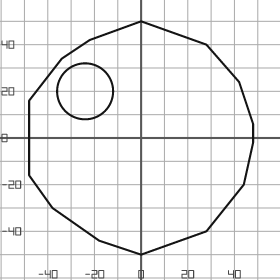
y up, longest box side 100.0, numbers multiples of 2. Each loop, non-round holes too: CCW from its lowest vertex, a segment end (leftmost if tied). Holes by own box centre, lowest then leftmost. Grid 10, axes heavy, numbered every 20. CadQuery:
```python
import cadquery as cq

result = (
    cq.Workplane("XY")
    .moveTo(0.0, -50.0)
    .lineTo(28.0, -40.0)
    .lineTo(44.0, -20.0)
    .lineTo(48.0, -2.0)
    .lineTo(48.0, 6.0)
    .lineTo(42.0, 24.0)
    .lineTo(28.0, 40.0)
    .lineTo(0.0, 50.0)
    .lineTo(-22.0, 42.0)
    .lineTo(-34.0, 34.0)
    .lineTo(-48.0, 16.0)
    .lineTo(-48.0, -16.0)
    .lineTo(-38.0, -30.0)
    .lineTo(-18.0, -44.0)
    .close()
    .moveTo(-24.0, 20.0)
    .circle(12.0)
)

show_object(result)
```